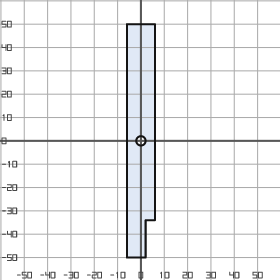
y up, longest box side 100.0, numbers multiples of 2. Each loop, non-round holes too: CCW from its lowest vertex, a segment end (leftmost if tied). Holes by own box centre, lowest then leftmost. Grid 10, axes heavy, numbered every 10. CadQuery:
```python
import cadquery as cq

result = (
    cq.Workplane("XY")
    .moveTo(-6.0, -50.0)
    .lineTo(2.0, -50.0)
    .lineTo(2.0, -34.0)
    .lineTo(6.0, -34.0)
    .lineTo(6.0, 50.0)
    .lineTo(-6.0, 50.0)
    .close()
    .moveTo(0.0, 0.0)
    .circle(2.0)
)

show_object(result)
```